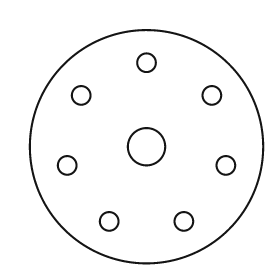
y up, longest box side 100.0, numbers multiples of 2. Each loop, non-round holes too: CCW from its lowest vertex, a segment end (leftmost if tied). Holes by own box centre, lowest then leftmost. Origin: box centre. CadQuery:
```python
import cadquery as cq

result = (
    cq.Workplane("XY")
    .moveTo(0.0, 0.0)
    .circle(50.0)
    .moveTo(-16.0, -32.0)
    .circle(4.0)
    .moveTo(16.0, -32.0)
    .circle(4.0)
    .moveTo(-34.0, -8.0)
    .circle(4.0)
    .moveTo(34.0, -8.0)
    .circle(4.0)
    .moveTo(0.0, 0.0)
    .circle(8.0)
    .moveTo(-28.0, 22.0)
    .circle(4.0)
    .moveTo(28.0, 22.0)
    .circle(4.0)
    .moveTo(0.0, 36.0)
    .circle(4.0)
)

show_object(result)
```